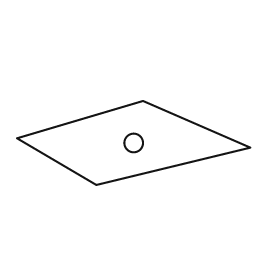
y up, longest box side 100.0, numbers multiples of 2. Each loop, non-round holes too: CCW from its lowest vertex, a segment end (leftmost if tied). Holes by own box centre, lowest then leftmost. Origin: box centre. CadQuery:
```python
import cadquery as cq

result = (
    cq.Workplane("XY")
    .moveTo(-16.0, -18.0)
    .lineTo(50.0, -2.0)
    .lineTo(4.0, 18.0)
    .lineTo(-50.0, 2.0)
    .close()
    .moveTo(0.0, 0.0)
    .circle(4.0)
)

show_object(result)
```